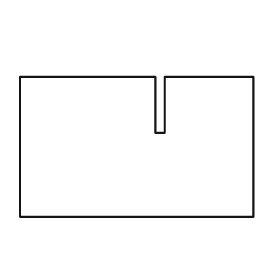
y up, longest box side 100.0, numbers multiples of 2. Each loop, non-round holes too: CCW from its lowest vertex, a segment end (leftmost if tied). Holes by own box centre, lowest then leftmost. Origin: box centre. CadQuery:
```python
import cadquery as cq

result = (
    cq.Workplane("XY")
    .moveTo(-50.0, -30.0)
    .lineTo(50.0, -30.0)
    .lineTo(50.0, 30.0)
    .lineTo(12.0, 30.0)
    .lineTo(12.0, 6.0)
    .lineTo(8.0, 6.0)
    .lineTo(8.0, 30.0)
    .lineTo(-50.0, 30.0)
    .close()
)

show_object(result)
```